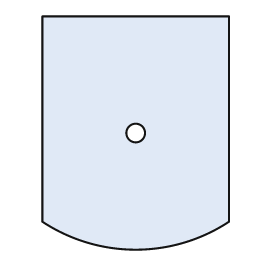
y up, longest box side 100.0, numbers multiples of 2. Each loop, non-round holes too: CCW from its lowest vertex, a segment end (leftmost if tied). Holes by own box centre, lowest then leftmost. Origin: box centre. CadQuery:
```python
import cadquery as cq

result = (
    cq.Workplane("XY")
    .moveTo(-40.0, -38.0)
    .threePointArc((0.0, -50.0), (40.0, -38.0))
    .lineTo(40.0, 50.0)
    .lineTo(-40.0, 50.0)
    .close()
    .moveTo(0.0, 0.0)
    .circle(4.0)
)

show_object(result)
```